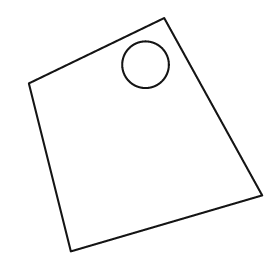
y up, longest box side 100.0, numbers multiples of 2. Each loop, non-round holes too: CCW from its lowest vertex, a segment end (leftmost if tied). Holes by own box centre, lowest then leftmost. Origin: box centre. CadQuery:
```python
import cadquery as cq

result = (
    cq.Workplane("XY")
    .moveTo(-32.0, -50.0)
    .lineTo(50.0, -26.0)
    .lineTo(8.0, 50.0)
    .lineTo(-50.0, 22.0)
    .close()
    .moveTo(0.0, 30.0)
    .circle(10.0)
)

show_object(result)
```